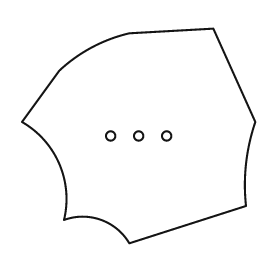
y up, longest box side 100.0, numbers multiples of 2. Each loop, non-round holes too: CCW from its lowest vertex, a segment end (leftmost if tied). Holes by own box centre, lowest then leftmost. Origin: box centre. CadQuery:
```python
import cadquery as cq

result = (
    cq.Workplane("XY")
    .moveTo(-4.0, -46.0)
    .lineTo(46.0, -30.0)
    .threePointArc((46.0, -12.0), (50.0, 6.0))
    .lineTo(32.0, 46.0)
    .lineTo(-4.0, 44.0)
    .threePointArc((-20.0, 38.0), (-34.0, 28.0))
    .lineTo(-50.0, 6.0)
    .threePointArc((-34.0, -12.0), (-32.0, -36.0))
    .threePointArc((-16.0, -36.0), (-4.0, -46.0))
    .close()
    .moveTo(-12.0, 0.0)
    .circle(2.0)
    .moveTo(0.0, 0.0)
    .circle(2.0)
    .moveTo(12.0, 0.0)
    .circle(2.0)
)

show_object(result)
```